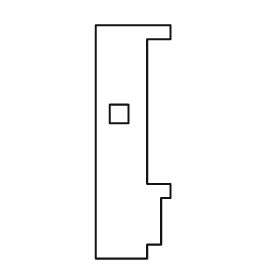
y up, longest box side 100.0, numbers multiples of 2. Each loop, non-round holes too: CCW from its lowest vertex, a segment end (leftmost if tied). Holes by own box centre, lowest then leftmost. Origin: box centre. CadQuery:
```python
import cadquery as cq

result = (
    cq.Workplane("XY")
    .moveTo(-16.0, -50.0)
    .lineTo(6.0, -50.0)
    .lineTo(6.0, -44.0)
    .lineTo(12.0, -44.0)
    .lineTo(12.0, -24.0)
    .lineTo(16.0, -24.0)
    .lineTo(16.0, -18.0)
    .lineTo(6.0, -18.0)
    .lineTo(6.0, 44.0)
    .lineTo(16.0, 44.0)
    .lineTo(16.0, 50.0)
    .lineTo(-16.0, 50.0)
    .close()
    .moveTo(-10.0, 8.0)
    .lineTo(-2.0, 8.0)
    .lineTo(-2.0, 16.0)
    .lineTo(-10.0, 16.0)
    .close()
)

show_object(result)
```